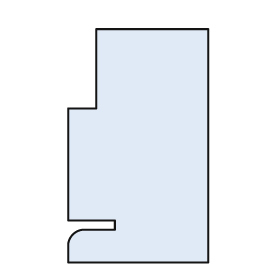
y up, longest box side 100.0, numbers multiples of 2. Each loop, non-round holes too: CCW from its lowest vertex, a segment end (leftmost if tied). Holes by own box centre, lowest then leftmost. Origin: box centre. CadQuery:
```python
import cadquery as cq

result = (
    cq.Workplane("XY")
    .moveTo(-30.0, -50.0)
    .lineTo(30.0, -50.0)
    .lineTo(30.0, 50.0)
    .lineTo(-18.0, 50.0)
    .lineTo(-18.0, 16.0)
    .lineTo(-30.0, 16.0)
    .lineTo(-30.0, -32.0)
    .lineTo(-10.0, -32.0)
    .lineTo(-10.0, -36.0)
    .lineTo(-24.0, -36.0)
    .threePointArc((-28.0, -38.0), (-30.0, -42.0))
    .close()
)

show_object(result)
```